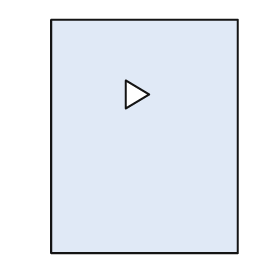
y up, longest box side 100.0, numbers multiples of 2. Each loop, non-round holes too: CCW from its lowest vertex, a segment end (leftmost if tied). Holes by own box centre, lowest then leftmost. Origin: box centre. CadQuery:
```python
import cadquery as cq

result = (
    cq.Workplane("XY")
    .moveTo(-40.0, -50.0)
    .lineTo(40.0, -50.0)
    .lineTo(40.0, 50.0)
    .lineTo(-40.0, 50.0)
    .close()
    .moveTo(-8.0, 12.0)
    .lineTo(2.0, 18.0)
    .lineTo(-8.0, 24.0)
    .close()
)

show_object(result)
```